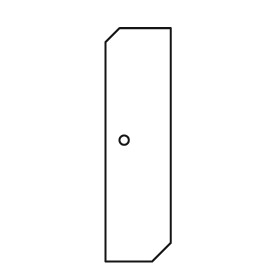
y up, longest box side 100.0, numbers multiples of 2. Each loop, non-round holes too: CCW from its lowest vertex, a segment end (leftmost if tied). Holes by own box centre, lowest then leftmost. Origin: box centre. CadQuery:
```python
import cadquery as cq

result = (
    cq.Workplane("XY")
    .moveTo(-14.0, -50.0)
    .lineTo(6.0, -50.0)
    .lineTo(14.0, -42.0)
    .lineTo(14.0, 50.0)
    .lineTo(-8.0, 50.0)
    .lineTo(-14.0, 44.0)
    .close()
    .moveTo(-6.0, 2.0)
    .circle(2.0)
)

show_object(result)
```